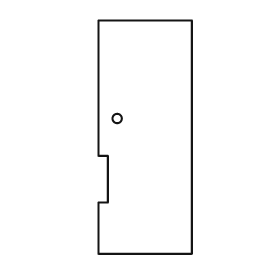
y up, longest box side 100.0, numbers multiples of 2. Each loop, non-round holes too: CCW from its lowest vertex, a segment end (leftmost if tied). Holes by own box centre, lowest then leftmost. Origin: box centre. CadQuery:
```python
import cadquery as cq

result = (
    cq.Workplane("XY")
    .moveTo(-20.0, -50.0)
    .lineTo(20.0, -50.0)
    .lineTo(20.0, 50.0)
    .lineTo(-20.0, 50.0)
    .lineTo(-20.0, -8.0)
    .lineTo(-16.0, -8.0)
    .lineTo(-16.0, -28.0)
    .lineTo(-20.0, -28.0)
    .close()
    .moveTo(-12.0, 8.0)
    .circle(2.0)
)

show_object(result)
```